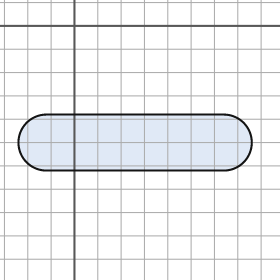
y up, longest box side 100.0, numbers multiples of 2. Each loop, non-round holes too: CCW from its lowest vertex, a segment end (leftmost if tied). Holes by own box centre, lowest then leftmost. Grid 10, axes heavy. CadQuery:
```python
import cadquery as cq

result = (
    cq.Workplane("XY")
    .moveTo(-12.0, -62.0)
    .lineTo(64.0, -62.0)
    .threePointArc((76.0, -50.0), (64.0, -38.0))
    .lineTo(-12.0, -38.0)
    .threePointArc((-24.0, -50.0), (-12.0, -62.0))
    .close()
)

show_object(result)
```